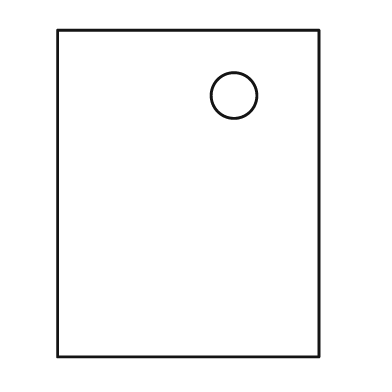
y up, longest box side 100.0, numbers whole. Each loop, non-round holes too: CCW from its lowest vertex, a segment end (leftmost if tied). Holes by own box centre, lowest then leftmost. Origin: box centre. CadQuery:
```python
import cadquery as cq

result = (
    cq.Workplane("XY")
    .moveTo(-40.0, -50.0)
    .lineTo(40.0, -50.0)
    .lineTo(40.0, 50.0)
    .lineTo(-40.0, 50.0)
    .close()
    .moveTo(14.0, 30.0)
    .circle(7.0)
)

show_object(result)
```